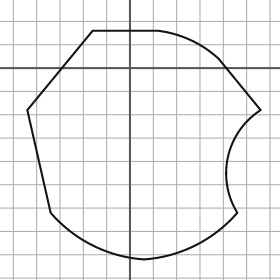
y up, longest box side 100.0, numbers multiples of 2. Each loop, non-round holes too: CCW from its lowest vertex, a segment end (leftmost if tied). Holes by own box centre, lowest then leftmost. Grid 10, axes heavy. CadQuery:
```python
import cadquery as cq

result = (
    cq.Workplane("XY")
    .moveTo(6.0, -82.0)
    .threePointArc((28.0, -76.0), (46.0, -62.0))
    .threePointArc((42.0, -38.0), (56.0, -18.0))
    .lineTo(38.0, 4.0)
    .threePointArc((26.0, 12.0), (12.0, 16.0))
    .lineTo(-16.0, 16.0)
    .lineTo(-44.0, -18.0)
    .lineTo(-34.0, -62.0)
    .threePointArc((-16.0, -76.0), (6.0, -82.0))
    .close()
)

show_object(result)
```